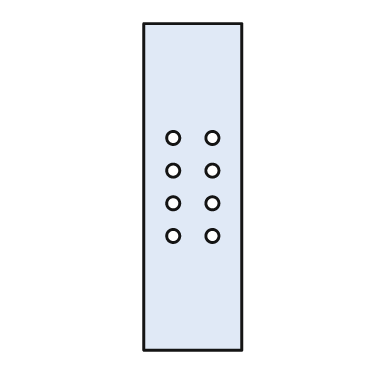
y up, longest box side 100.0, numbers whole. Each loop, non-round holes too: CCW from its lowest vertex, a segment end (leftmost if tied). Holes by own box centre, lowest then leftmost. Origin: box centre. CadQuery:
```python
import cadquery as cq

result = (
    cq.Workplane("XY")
    .moveTo(-15.0, -50.0)
    .lineTo(15.0, -50.0)
    .lineTo(15.0, 50.0)
    .lineTo(-15.0, 50.0)
    .close()
    .moveTo(-6.0, -15.0)
    .circle(2.0)
    .moveTo(6.0, -15.0)
    .circle(2.0)
    .moveTo(-6.0, -5.0)
    .circle(2.0)
    .moveTo(6.0, -5.0)
    .circle(2.0)
    .moveTo(-6.0, 5.0)
    .circle(2.0)
    .moveTo(6.0, 5.0)
    .circle(2.0)
    .moveTo(-6.0, 15.0)
    .circle(2.0)
    .moveTo(6.0, 15.0)
    .circle(2.0)
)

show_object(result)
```